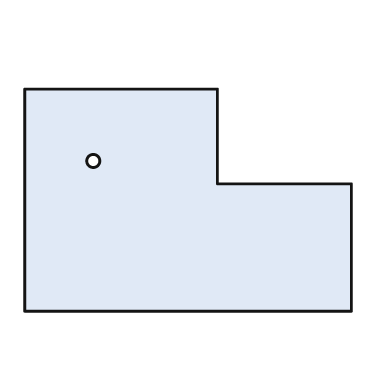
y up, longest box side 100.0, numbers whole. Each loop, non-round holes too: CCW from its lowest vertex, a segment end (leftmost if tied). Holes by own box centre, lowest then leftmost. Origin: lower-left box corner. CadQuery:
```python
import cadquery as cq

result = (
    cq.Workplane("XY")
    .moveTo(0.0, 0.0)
    .lineTo(100.0, 0.0)
    .lineTo(100.0, 39.0)
    .lineTo(59.0, 39.0)
    .lineTo(59.0, 68.0)
    .lineTo(0.0, 68.0)
    .close()
    .moveTo(21.0, 46.0)
    .circle(2.0)
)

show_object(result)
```